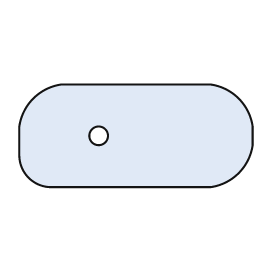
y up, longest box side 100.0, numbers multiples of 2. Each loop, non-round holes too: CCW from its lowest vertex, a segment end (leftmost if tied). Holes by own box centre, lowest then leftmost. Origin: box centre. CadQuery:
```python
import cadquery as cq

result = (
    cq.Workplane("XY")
    .moveTo(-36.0, -22.0)
    .lineTo(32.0, -22.0)
    .threePointArc((44.0, -16.0), (50.0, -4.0))
    .lineTo(50.0, 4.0)
    .threePointArc((44.0, 16.0), (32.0, 22.0))
    .lineTo(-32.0, 22.0)
    .threePointArc((-44.0, 16.0), (-50.0, 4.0))
    .lineTo(-50.0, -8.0)
    .threePointArc((-46.0, -18.0), (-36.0, -22.0))
    .close()
    .moveTo(-16.0, 0.0)
    .circle(4.0)
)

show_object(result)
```